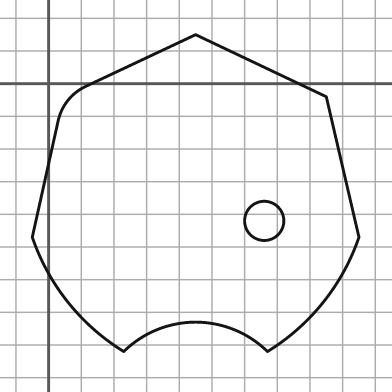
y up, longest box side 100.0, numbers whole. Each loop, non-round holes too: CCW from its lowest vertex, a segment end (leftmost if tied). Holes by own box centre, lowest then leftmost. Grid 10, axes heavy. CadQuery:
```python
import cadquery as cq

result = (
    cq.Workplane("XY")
    .moveTo(23.0, -82.0)
    .threePointArc((45.0, -73.0), (67.0, -82.0))
    .threePointArc((84.0, -67.0), (95.0, -47.0))
    .lineTo(85.0, -4.0)
    .lineTo(45.0, 15.0)
    .lineTo(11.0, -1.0)
    .threePointArc((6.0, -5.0), (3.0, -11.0))
    .lineTo(-5.0, -47.0)
    .threePointArc((6.0, -67.0), (23.0, -82.0))
    .close()
    .moveTo(66.0, -42.0)
    .circle(6.0)
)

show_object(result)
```